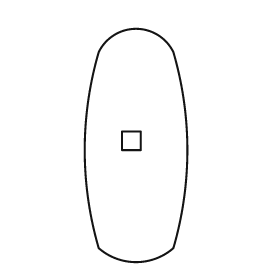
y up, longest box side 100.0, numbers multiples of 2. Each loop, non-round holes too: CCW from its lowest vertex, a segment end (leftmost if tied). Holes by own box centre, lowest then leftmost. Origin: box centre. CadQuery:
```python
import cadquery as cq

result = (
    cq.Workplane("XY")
    .moveTo(-16.0, -44.0)
    .threePointArc((0.0, -50.0), (16.0, -44.0))
    .threePointArc((22.0, -2.0), (16.0, 40.0))
    .threePointArc((0.0, 50.0), (-16.0, 40.0))
    .threePointArc((-22.0, -2.0), (-16.0, -44.0))
    .close()
    .moveTo(-6.0, -2.0)
    .lineTo(2.0, -2.0)
    .lineTo(2.0, 6.0)
    .lineTo(-6.0, 6.0)
    .close()
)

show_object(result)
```